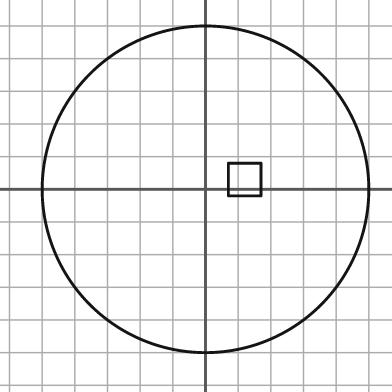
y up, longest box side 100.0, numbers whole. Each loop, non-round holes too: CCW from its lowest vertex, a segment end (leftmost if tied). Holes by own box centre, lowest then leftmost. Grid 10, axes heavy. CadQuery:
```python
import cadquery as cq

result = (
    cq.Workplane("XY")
    .moveTo(0.0, 0.0)
    .circle(50.0)
    .moveTo(7.0, -2.0)
    .lineTo(17.0, -2.0)
    .lineTo(17.0, 8.0)
    .lineTo(7.0, 8.0)
    .close()
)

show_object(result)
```